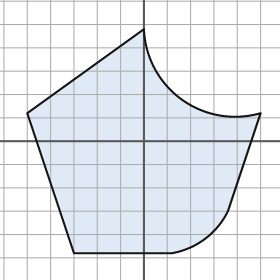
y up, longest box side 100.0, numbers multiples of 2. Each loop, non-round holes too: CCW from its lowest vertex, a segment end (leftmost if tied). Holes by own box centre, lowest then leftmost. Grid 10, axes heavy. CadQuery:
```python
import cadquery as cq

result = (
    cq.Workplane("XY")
    .moveTo(-30.0, -48.0)
    .lineTo(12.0, -48.0)
    .threePointArc((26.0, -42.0), (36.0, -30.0))
    .lineTo(50.0, 12.0)
    .threePointArc((16.0, 18.0), (0.0, 48.0))
    .lineTo(-50.0, 12.0)
    .close()
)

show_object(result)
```